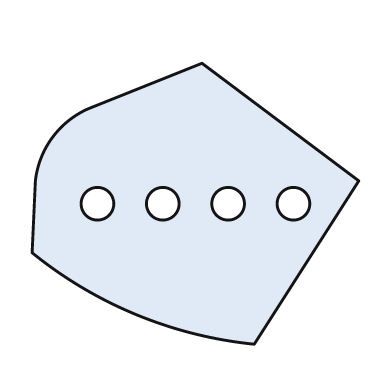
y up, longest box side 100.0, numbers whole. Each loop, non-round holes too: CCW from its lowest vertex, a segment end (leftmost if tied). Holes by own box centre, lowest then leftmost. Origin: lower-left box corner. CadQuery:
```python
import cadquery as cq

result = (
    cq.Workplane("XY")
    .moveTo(68.0, 0.0)
    .lineTo(100.0, 50.0)
    .lineTo(52.0, 86.0)
    .lineTo(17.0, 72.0)
    .threePointArc((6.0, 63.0), (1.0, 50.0))
    .lineTo(0.0, 28.0)
    .threePointArc((32.0, 9.0), (68.0, 0.0))
    .close()
    .moveTo(20.0, 43.0)
    .circle(5.0)
    .moveTo(40.0, 43.0)
    .circle(5.0)
    .moveTo(60.0, 43.0)
    .circle(5.0)
    .moveTo(80.0, 43.0)
    .circle(5.0)
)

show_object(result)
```